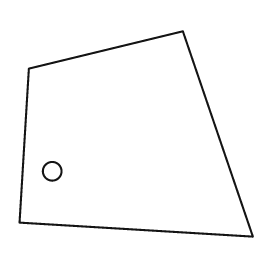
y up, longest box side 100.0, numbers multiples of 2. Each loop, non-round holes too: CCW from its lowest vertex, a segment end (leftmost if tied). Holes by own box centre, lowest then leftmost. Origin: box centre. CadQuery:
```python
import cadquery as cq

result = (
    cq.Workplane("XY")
    .moveTo(50.0, -44.0)
    .lineTo(20.0, 44.0)
    .lineTo(-46.0, 28.0)
    .lineTo(-50.0, -38.0)
    .close()
    .moveTo(-36.0, -16.0)
    .circle(4.0)
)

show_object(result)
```